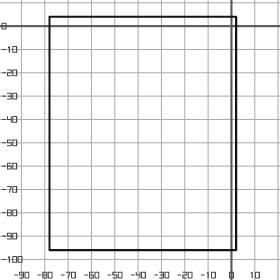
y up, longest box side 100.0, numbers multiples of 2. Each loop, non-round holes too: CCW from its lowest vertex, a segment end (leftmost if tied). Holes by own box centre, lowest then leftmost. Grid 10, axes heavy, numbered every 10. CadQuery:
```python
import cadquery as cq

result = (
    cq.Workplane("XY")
    .moveTo(-78.0, -96.0)
    .lineTo(2.0, -96.0)
    .lineTo(2.0, 4.0)
    .lineTo(-78.0, 4.0)
    .close()
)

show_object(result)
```